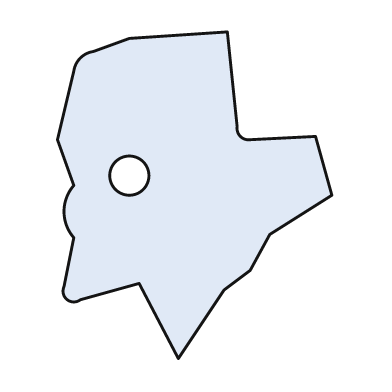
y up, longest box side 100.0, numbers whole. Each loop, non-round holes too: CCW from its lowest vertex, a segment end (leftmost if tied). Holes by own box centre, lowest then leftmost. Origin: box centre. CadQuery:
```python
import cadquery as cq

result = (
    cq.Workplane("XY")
    .moveTo(-5.0, -50.0)
    .lineTo(9.0, -29.0)
    .lineTo(17.0, -23.0)
    .lineTo(23.0, -12.0)
    .lineTo(42.0, 0.0)
    .lineTo(37.0, 18.0)
    .lineTo(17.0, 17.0)
    .threePointArc((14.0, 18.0), (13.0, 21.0))
    .lineTo(10.0, 50.0)
    .lineTo(-20.0, 48.0)
    .lineTo(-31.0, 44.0)
    .threePointArc((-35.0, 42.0), (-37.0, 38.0))
    .lineTo(-42.0, 17.0)
    .lineTo(-37.0, 3.0)
    .threePointArc((-40.0, -5.0), (-37.0, -13.0))
    .lineTo(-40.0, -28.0)
    .threePointArc((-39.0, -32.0), (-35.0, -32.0))
    .lineTo(-17.0, -27.0)
    .close()
    .moveTo(-20.0, 6.0)
    .circle(6.0)
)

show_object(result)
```